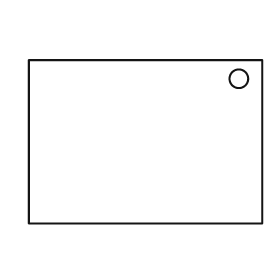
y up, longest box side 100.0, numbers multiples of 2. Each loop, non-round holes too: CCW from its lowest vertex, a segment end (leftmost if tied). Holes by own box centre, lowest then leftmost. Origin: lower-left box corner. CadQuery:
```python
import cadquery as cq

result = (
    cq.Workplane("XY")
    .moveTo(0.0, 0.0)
    .lineTo(100.0, 0.0)
    .lineTo(100.0, 70.0)
    .lineTo(0.0, 70.0)
    .close()
    .moveTo(90.0, 62.0)
    .circle(4.0)
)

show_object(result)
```